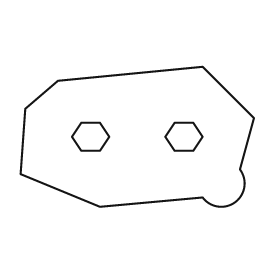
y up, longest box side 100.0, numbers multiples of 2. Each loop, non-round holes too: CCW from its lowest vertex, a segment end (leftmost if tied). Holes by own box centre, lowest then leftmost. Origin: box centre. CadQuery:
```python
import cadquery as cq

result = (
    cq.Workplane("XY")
    .moveTo(-16.0, -30.0)
    .lineTo(28.0, -26.0)
    .threePointArc((42.0, -28.0), (44.0, -14.0))
    .lineTo(50.0, 8.0)
    .lineTo(28.0, 30.0)
    .lineTo(-34.0, 24.0)
    .lineTo(-48.0, 12.0)
    .lineTo(-50.0, -16.0)
    .close()
    .moveTo(-24.0, -6.0)
    .lineTo(-16.0, -6.0)
    .lineTo(-12.0, 0.0)
    .lineTo(-16.0, 6.0)
    .lineTo(-24.0, 6.0)
    .lineTo(-28.0, 0.0)
    .close()
    .moveTo(16.0, -6.0)
    .lineTo(24.0, -6.0)
    .lineTo(28.0, 0.0)
    .lineTo(24.0, 6.0)
    .lineTo(16.0, 6.0)
    .lineTo(12.0, 0.0)
    .close()
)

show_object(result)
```